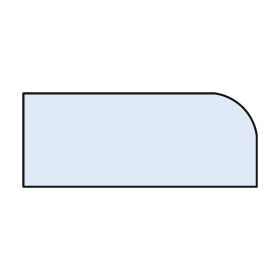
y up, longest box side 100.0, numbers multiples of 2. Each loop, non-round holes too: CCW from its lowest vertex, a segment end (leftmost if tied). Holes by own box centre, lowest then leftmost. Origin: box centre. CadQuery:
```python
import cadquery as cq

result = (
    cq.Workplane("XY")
    .moveTo(-50.0, -20.0)
    .lineTo(50.0, -20.0)
    .lineTo(50.0, 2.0)
    .threePointArc((44.0, 14.0), (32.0, 20.0))
    .lineTo(-50.0, 20.0)
    .close()
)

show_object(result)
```